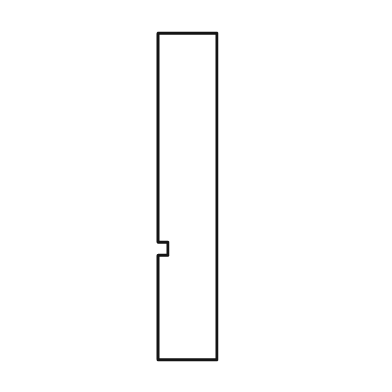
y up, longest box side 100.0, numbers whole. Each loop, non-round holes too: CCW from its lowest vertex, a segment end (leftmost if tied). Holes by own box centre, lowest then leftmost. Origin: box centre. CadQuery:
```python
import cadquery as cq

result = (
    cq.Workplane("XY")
    .moveTo(-9.0, -50.0)
    .lineTo(9.0, -50.0)
    .lineTo(9.0, 50.0)
    .lineTo(-9.0, 50.0)
    .lineTo(-9.0, -14.0)
    .lineTo(-6.0, -14.0)
    .lineTo(-6.0, -18.0)
    .lineTo(-9.0, -18.0)
    .close()
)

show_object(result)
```